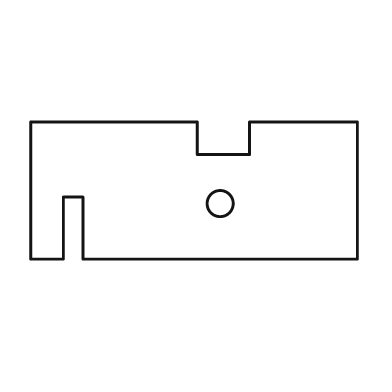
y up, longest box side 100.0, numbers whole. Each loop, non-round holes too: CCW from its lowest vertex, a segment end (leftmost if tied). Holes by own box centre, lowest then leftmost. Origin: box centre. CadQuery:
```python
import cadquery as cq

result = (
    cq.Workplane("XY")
    .moveTo(-50.0, -21.0)
    .lineTo(-40.0, -21.0)
    .lineTo(-40.0, -2.0)
    .lineTo(-34.0, -2.0)
    .lineTo(-34.0, -21.0)
    .lineTo(50.0, -21.0)
    .lineTo(50.0, 21.0)
    .lineTo(17.0, 21.0)
    .lineTo(17.0, 11.0)
    .lineTo(1.0, 11.0)
    .lineTo(1.0, 21.0)
    .lineTo(-50.0, 21.0)
    .close()
    .moveTo(8.0, -4.0)
    .circle(4.0)
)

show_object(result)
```